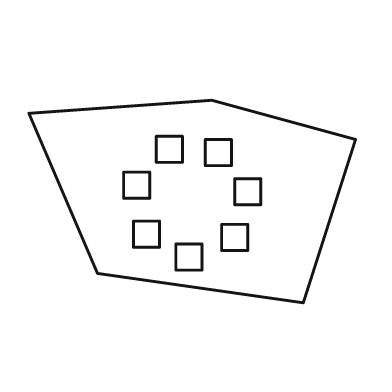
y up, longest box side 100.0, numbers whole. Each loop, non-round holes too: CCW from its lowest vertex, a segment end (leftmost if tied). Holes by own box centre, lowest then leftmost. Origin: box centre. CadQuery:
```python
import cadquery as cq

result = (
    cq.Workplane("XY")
    .moveTo(34.0, -31.0)
    .lineTo(50.0, 19.0)
    .lineTo(6.0, 31.0)
    .lineTo(-50.0, 27.0)
    .lineTo(-29.0, -22.0)
    .close()
    .moveTo(-5.0, -21.0)
    .lineTo(3.0, -21.0)
    .lineTo(3.0, -13.0)
    .lineTo(-5.0, -13.0)
    .close()
    .moveTo(9.0, -15.0)
    .lineTo(17.0, -15.0)
    .lineTo(17.0, -7.0)
    .lineTo(9.0, -7.0)
    .close()
    .moveTo(-18.0, -14.0)
    .lineTo(-10.0, -14.0)
    .lineTo(-10.0, -6.0)
    .lineTo(-18.0, -6.0)
    .close()
    .moveTo(13.0, -1.0)
    .lineTo(21.0, -1.0)
    .lineTo(21.0, 7.0)
    .lineTo(13.0, 7.0)
    .close()
    .moveTo(-21.0, 1.0)
    .lineTo(-13.0, 1.0)
    .lineTo(-13.0, 9.0)
    .lineTo(-21.0, 9.0)
    .close()
    .moveTo(4.0, 11.0)
    .lineTo(12.0, 11.0)
    .lineTo(12.0, 19.0)
    .lineTo(4.0, 19.0)
    .close()
    .moveTo(-11.0, 12.0)
    .lineTo(-3.0, 12.0)
    .lineTo(-3.0, 20.0)
    .lineTo(-11.0, 20.0)
    .close()
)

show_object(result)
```